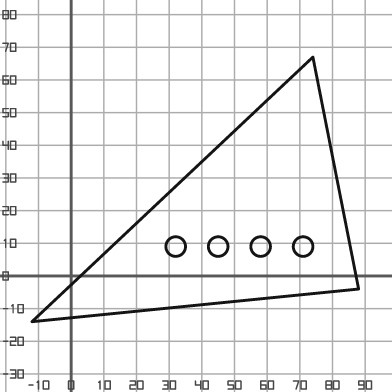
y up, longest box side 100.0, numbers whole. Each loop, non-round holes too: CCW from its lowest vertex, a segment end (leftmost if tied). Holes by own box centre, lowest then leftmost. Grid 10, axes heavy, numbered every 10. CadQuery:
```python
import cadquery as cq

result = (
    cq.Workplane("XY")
    .moveTo(-12.0, -14.0)
    .lineTo(88.0, -4.0)
    .lineTo(74.0, 67.0)
    .close()
    .moveTo(32.0, 9.0)
    .circle(3.0)
    .moveTo(45.0, 9.0)
    .circle(3.0)
    .moveTo(58.0, 9.0)
    .circle(3.0)
    .moveTo(71.0, 9.0)
    .circle(3.0)
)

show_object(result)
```